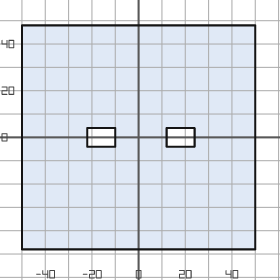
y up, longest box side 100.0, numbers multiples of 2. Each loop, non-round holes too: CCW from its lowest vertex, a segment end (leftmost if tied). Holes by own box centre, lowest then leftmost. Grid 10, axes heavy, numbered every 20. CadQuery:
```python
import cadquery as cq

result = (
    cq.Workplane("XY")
    .moveTo(-50.0, -48.0)
    .lineTo(50.0, -48.0)
    .lineTo(50.0, 48.0)
    .lineTo(-50.0, 48.0)
    .close()
    .moveTo(-22.0, -4.0)
    .lineTo(-10.0, -4.0)
    .lineTo(-10.0, 4.0)
    .lineTo(-22.0, 4.0)
    .close()
    .moveTo(12.0, -4.0)
    .lineTo(24.0, -4.0)
    .lineTo(24.0, 4.0)
    .lineTo(12.0, 4.0)
    .close()
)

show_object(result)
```